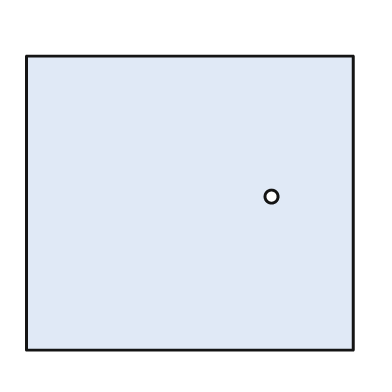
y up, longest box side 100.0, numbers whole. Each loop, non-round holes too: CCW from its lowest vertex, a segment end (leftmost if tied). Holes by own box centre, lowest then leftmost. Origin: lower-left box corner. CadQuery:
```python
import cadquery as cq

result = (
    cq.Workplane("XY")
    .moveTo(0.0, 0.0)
    .lineTo(100.0, 0.0)
    .lineTo(100.0, 90.0)
    .lineTo(0.0, 90.0)
    .close()
    .moveTo(75.0, 47.0)
    .circle(2.0)
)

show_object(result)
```